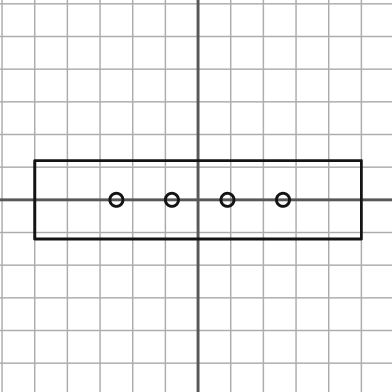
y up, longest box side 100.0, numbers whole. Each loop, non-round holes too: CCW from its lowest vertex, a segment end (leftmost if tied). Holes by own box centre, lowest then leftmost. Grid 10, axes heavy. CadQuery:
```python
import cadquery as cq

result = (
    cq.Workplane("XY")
    .moveTo(-50.0, -12.0)
    .lineTo(50.0, -12.0)
    .lineTo(50.0, 12.0)
    .lineTo(-50.0, 12.0)
    .close()
    .moveTo(-25.0, 0.0)
    .circle(2.0)
    .moveTo(-8.0, 0.0)
    .circle(2.0)
    .moveTo(9.0, 0.0)
    .circle(2.0)
    .moveTo(26.0, 0.0)
    .circle(2.0)
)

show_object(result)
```